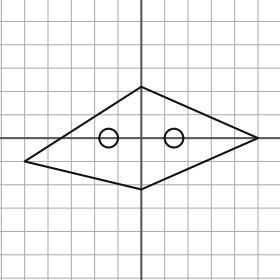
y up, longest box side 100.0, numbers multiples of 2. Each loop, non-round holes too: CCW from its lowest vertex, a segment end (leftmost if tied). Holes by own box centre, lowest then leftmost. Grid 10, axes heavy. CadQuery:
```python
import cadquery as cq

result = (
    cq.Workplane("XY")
    .moveTo(0.0, -22.0)
    .lineTo(50.0, 0.0)
    .lineTo(0.0, 22.0)
    .lineTo(-50.0, -10.0)
    .close()
    .moveTo(-14.0, 0.0)
    .circle(4.0)
    .moveTo(14.0, 0.0)
    .circle(4.0)
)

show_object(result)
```